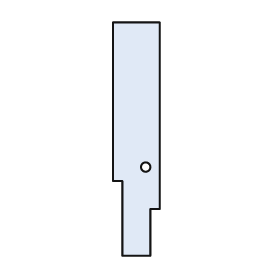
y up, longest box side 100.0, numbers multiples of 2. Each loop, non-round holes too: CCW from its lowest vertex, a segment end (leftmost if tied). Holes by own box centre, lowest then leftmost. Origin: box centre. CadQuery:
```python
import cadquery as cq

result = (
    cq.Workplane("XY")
    .moveTo(-6.0, -50.0)
    .lineTo(6.0, -50.0)
    .lineTo(6.0, -30.0)
    .lineTo(10.0, -30.0)
    .lineTo(10.0, 50.0)
    .lineTo(-10.0, 50.0)
    .lineTo(-10.0, -18.0)
    .lineTo(-6.0, -18.0)
    .close()
    .moveTo(4.0, -12.0)
    .circle(2.0)
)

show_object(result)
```